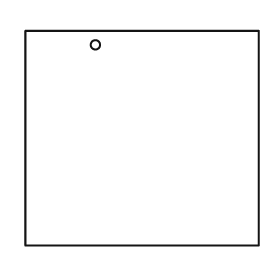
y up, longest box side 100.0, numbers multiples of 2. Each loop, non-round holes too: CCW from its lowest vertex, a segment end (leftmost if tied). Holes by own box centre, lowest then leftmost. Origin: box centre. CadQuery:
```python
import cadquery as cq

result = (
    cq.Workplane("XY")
    .moveTo(-50.0, -46.0)
    .lineTo(50.0, -46.0)
    .lineTo(50.0, 46.0)
    .lineTo(-50.0, 46.0)
    .close()
    .moveTo(-20.0, 40.0)
    .circle(2.0)
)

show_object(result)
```